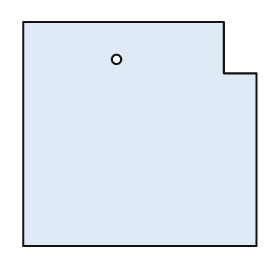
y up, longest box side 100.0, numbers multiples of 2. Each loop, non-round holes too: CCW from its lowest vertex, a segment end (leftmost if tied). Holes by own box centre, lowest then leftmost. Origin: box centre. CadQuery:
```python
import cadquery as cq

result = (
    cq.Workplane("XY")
    .moveTo(-50.0, -48.0)
    .lineTo(50.0, -48.0)
    .lineTo(50.0, 26.0)
    .lineTo(36.0, 26.0)
    .lineTo(36.0, 48.0)
    .lineTo(-50.0, 48.0)
    .close()
    .moveTo(-10.0, 32.0)
    .circle(2.0)
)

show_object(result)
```